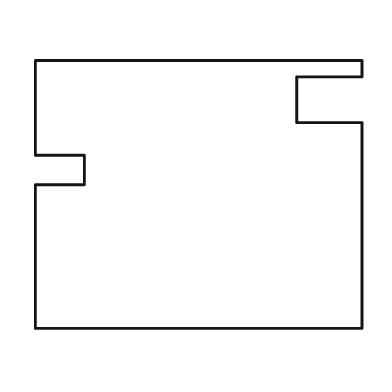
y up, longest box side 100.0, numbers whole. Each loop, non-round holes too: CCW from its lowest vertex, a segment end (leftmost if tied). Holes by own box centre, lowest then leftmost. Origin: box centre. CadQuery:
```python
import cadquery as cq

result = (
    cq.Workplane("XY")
    .moveTo(-50.0, -41.0)
    .lineTo(50.0, -41.0)
    .lineTo(50.0, 22.0)
    .lineTo(30.0, 22.0)
    .lineTo(30.0, 36.0)
    .lineTo(50.0, 36.0)
    .lineTo(50.0, 41.0)
    .lineTo(-50.0, 41.0)
    .lineTo(-50.0, 12.0)
    .lineTo(-35.0, 12.0)
    .lineTo(-35.0, 3.0)
    .lineTo(-50.0, 3.0)
    .close()
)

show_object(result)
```